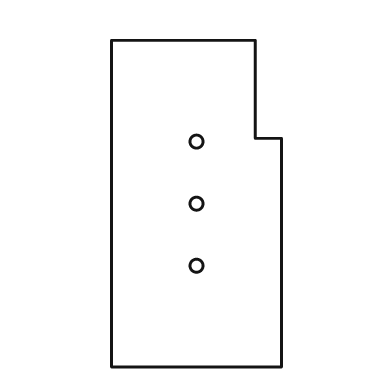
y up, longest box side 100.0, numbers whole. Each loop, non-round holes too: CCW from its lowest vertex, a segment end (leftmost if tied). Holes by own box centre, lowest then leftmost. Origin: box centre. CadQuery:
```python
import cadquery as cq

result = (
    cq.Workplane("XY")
    .moveTo(-26.0, -50.0)
    .lineTo(26.0, -50.0)
    .lineTo(26.0, 20.0)
    .lineTo(18.0, 20.0)
    .lineTo(18.0, 50.0)
    .lineTo(-26.0, 50.0)
    .close()
    .moveTo(0.0, -19.0)
    .circle(2.0)
    .moveTo(0.0, 0.0)
    .circle(2.0)
    .moveTo(0.0, 19.0)
    .circle(2.0)
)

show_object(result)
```